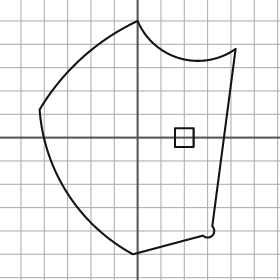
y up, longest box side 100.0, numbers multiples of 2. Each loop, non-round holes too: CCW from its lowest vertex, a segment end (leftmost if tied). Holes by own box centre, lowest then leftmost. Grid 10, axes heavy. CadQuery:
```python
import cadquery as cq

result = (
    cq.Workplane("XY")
    .moveTo(-2.0, -50.0)
    .lineTo(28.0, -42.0)
    .threePointArc((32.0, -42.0), (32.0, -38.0))
    .lineTo(42.0, 38.0)
    .threePointArc((18.0, 34.0), (0.0, 50.0))
    .threePointArc((-24.0, 34.0), (-42.0, 12.0))
    .threePointArc((-30.0, -24.0), (-2.0, -50.0))
    .close()
    .moveTo(16.0, -4.0)
    .lineTo(24.0, -4.0)
    .lineTo(24.0, 4.0)
    .lineTo(16.0, 4.0)
    .close()
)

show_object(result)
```